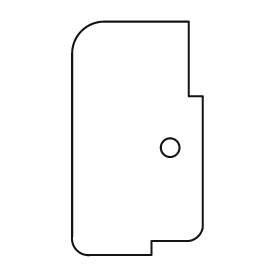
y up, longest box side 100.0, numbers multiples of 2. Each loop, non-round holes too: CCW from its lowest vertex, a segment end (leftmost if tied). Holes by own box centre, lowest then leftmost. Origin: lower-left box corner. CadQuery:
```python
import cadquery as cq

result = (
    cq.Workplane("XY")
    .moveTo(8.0, 0.0)
    .lineTo(34.0, 0.0)
    .lineTo(34.0, 6.0)
    .lineTo(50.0, 6.0)
    .threePointArc((54.0, 8.0), (56.0, 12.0))
    .lineTo(56.0, 68.0)
    .lineTo(50.0, 68.0)
    .lineTo(50.0, 100.0)
    .lineTo(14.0, 100.0)
    .threePointArc((4.0, 96.0), (0.0, 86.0))
    .lineTo(0.0, 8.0)
    .threePointArc((2.0, 2.0), (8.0, 0.0))
    .close()
    .moveTo(42.0, 46.0)
    .circle(4.0)
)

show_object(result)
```